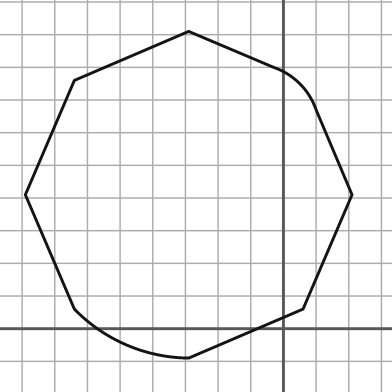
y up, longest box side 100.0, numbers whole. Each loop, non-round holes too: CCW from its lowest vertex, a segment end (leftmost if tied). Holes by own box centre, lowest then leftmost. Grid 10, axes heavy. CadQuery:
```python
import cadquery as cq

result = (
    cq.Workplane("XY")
    .moveTo(-29.0, -9.0)
    .lineTo(6.0, 6.0)
    .lineTo(21.0, 41.0)
    .lineTo(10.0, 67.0)
    .threePointArc((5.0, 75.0), (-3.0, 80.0))
    .lineTo(-29.0, 91.0)
    .lineTo(-64.0, 76.0)
    .lineTo(-79.0, 41.0)
    .lineTo(-64.0, 6.0)
    .threePointArc((-48.0, -5.0), (-29.0, -9.0))
    .close()
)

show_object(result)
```